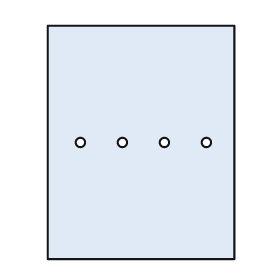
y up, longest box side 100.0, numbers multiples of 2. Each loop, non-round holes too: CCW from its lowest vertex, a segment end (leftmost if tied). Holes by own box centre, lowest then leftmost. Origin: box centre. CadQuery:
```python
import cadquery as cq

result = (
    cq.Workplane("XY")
    .moveTo(-40.0, -50.0)
    .lineTo(40.0, -50.0)
    .lineTo(40.0, 50.0)
    .lineTo(-40.0, 50.0)
    .close()
    .moveTo(-26.0, 0.0)
    .circle(2.0)
    .moveTo(-8.0, 0.0)
    .circle(2.0)
    .moveTo(10.0, 0.0)
    .circle(2.0)
    .moveTo(28.0, 0.0)
    .circle(2.0)
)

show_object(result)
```